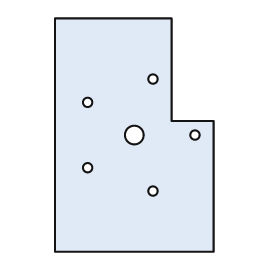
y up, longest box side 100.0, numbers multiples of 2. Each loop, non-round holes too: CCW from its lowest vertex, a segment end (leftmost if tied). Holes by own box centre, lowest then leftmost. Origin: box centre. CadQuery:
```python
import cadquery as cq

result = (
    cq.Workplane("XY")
    .moveTo(-34.0, -50.0)
    .lineTo(34.0, -50.0)
    .lineTo(34.0, 6.0)
    .lineTo(16.0, 6.0)
    .lineTo(16.0, 50.0)
    .lineTo(-34.0, 50.0)
    .close()
    .moveTo(8.0, -24.0)
    .circle(2.0)
    .moveTo(-20.0, -14.0)
    .circle(2.0)
    .moveTo(0.0, 0.0)
    .circle(4.0)
    .moveTo(26.0, 0.0)
    .circle(2.0)
    .moveTo(-20.0, 14.0)
    .circle(2.0)
    .moveTo(8.0, 24.0)
    .circle(2.0)
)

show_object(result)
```